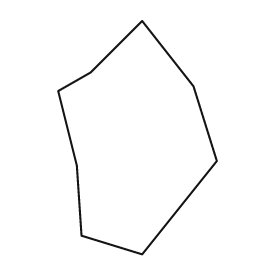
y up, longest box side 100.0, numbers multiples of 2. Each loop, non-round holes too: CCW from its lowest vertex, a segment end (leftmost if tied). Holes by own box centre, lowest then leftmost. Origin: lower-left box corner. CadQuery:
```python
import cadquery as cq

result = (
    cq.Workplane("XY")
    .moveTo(36.0, 0.0)
    .lineTo(68.0, 40.0)
    .lineTo(58.0, 72.0)
    .lineTo(36.0, 100.0)
    .lineTo(14.0, 78.0)
    .lineTo(0.0, 70.0)
    .lineTo(8.0, 38.0)
    .lineTo(10.0, 8.0)
    .close()
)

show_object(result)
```